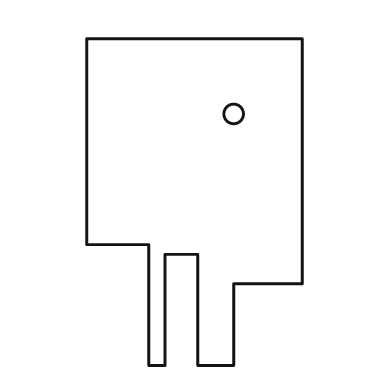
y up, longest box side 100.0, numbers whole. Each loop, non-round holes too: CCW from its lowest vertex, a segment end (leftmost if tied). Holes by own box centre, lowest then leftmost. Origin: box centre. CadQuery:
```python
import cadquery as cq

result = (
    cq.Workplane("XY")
    .moveTo(-14.0, -50.0)
    .lineTo(-9.0, -50.0)
    .lineTo(-9.0, -16.0)
    .lineTo(1.0, -16.0)
    .lineTo(1.0, -50.0)
    .lineTo(12.0, -50.0)
    .lineTo(12.0, -25.0)
    .lineTo(33.0, -25.0)
    .lineTo(33.0, 50.0)
    .lineTo(-33.0, 50.0)
    .lineTo(-33.0, -13.0)
    .lineTo(-14.0, -13.0)
    .close()
    .moveTo(12.0, 27.0)
    .circle(3.0)
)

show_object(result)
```